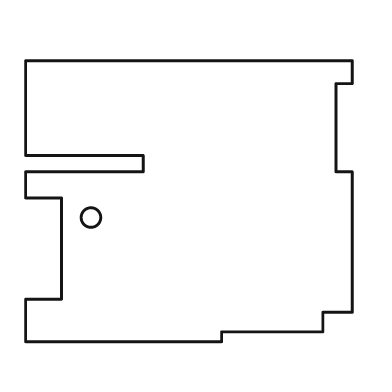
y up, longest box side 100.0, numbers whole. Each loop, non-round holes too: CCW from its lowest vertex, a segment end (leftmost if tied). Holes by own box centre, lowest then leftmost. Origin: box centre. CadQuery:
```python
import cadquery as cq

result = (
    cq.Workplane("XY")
    .moveTo(-50.0, -43.0)
    .lineTo(10.0, -43.0)
    .lineTo(10.0, -40.0)
    .lineTo(41.0, -40.0)
    .lineTo(41.0, -34.0)
    .lineTo(50.0, -34.0)
    .lineTo(50.0, 9.0)
    .lineTo(45.0, 9.0)
    .lineTo(45.0, 36.0)
    .lineTo(50.0, 36.0)
    .lineTo(50.0, 43.0)
    .lineTo(-50.0, 43.0)
    .lineTo(-50.0, 14.0)
    .lineTo(-14.0, 14.0)
    .lineTo(-14.0, 9.0)
    .lineTo(-50.0, 9.0)
    .lineTo(-50.0, 1.0)
    .lineTo(-39.0, 1.0)
    .lineTo(-39.0, -30.0)
    .lineTo(-50.0, -30.0)
    .close()
    .moveTo(-30.0, -5.0)
    .circle(3.0)
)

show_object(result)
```